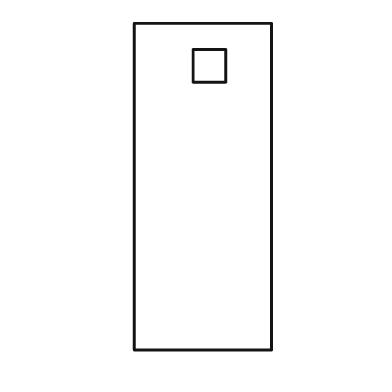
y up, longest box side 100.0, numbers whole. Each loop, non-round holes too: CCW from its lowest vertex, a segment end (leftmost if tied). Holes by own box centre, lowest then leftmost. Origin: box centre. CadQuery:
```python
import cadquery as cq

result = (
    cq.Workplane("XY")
    .moveTo(-21.0, -50.0)
    .lineTo(21.0, -50.0)
    .lineTo(21.0, 50.0)
    .lineTo(-21.0, 50.0)
    .close()
    .moveTo(-3.0, 32.0)
    .lineTo(7.0, 32.0)
    .lineTo(7.0, 42.0)
    .lineTo(-3.0, 42.0)
    .close()
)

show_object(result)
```